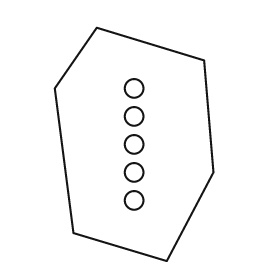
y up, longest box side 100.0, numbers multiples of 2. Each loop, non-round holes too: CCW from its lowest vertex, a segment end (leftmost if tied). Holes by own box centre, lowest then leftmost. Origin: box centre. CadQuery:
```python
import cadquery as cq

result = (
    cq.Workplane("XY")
    .moveTo(14.0, -50.0)
    .lineTo(34.0, -12.0)
    .lineTo(30.0, 36.0)
    .lineTo(-16.0, 50.0)
    .lineTo(-34.0, 24.0)
    .lineTo(-26.0, -38.0)
    .close()
    .moveTo(0.0, -24.0)
    .circle(4.0)
    .moveTo(0.0, -12.0)
    .circle(4.0)
    .moveTo(0.0, 0.0)
    .circle(4.0)
    .moveTo(0.0, 12.0)
    .circle(4.0)
    .moveTo(0.0, 24.0)
    .circle(4.0)
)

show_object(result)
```